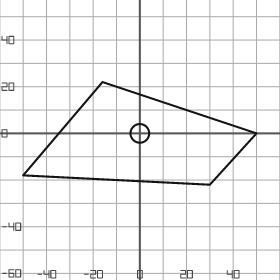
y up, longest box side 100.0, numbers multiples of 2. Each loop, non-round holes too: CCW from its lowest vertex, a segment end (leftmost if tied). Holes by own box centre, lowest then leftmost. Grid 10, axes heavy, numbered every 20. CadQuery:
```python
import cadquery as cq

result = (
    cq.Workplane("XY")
    .moveTo(30.0, -22.0)
    .lineTo(50.0, 0.0)
    .lineTo(-16.0, 22.0)
    .lineTo(-50.0, -18.0)
    .close()
    .moveTo(0.0, 0.0)
    .circle(4.0)
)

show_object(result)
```